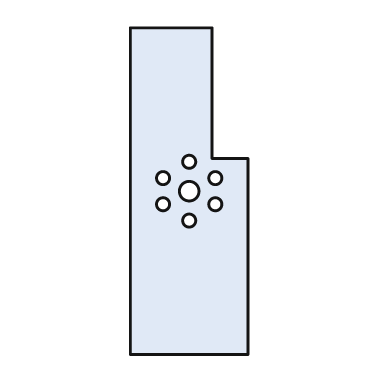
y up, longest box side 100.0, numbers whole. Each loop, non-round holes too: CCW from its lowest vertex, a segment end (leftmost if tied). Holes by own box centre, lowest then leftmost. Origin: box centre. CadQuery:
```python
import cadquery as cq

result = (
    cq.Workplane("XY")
    .moveTo(-18.0, -50.0)
    .lineTo(18.0, -50.0)
    .lineTo(18.0, 10.0)
    .lineTo(7.0, 10.0)
    .lineTo(7.0, 50.0)
    .lineTo(-18.0, 50.0)
    .close()
    .moveTo(0.0, -9.0)
    .circle(2.0)
    .moveTo(-8.0, -4.0)
    .circle(2.0)
    .moveTo(8.0, -4.0)
    .circle(2.0)
    .moveTo(0.0, 0.0)
    .circle(3.0)
    .moveTo(-8.0, 4.0)
    .circle(2.0)
    .moveTo(8.0, 4.0)
    .circle(2.0)
    .moveTo(0.0, 9.0)
    .circle(2.0)
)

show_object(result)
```